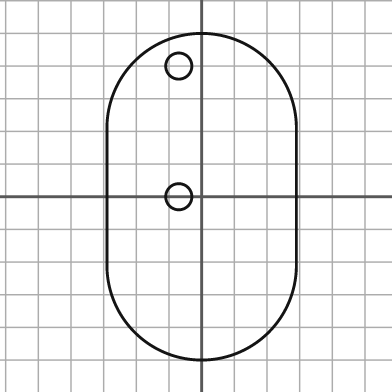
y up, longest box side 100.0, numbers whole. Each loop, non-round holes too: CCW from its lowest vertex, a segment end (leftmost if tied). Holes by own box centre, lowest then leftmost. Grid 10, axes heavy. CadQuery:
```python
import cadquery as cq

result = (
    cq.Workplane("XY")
    .moveTo(-29.0, -21.0)
    .threePointArc((0.0, -50.0), (29.0, -21.0))
    .lineTo(29.0, 21.0)
    .threePointArc((0.0, 50.0), (-29.0, 21.0))
    .close()
    .moveTo(-7.0, 0.0)
    .circle(4.0)
    .moveTo(-7.0, 40.0)
    .circle(4.0)
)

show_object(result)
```